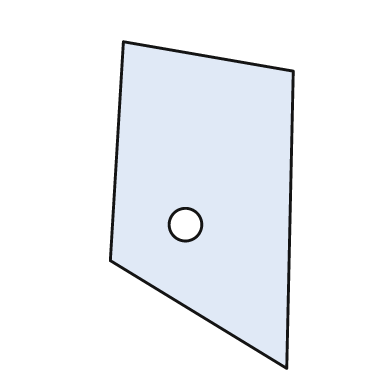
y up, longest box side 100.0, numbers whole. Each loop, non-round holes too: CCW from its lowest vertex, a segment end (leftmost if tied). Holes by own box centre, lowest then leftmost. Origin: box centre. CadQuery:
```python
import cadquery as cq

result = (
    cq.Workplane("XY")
    .moveTo(26.0, -50.0)
    .lineTo(28.0, 41.0)
    .lineTo(-24.0, 50.0)
    .lineTo(-28.0, -17.0)
    .close()
    .moveTo(-5.0, -6.0)
    .circle(5.0)
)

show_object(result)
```